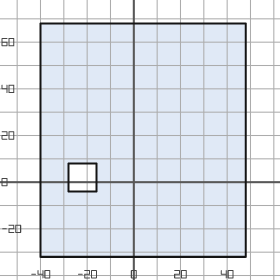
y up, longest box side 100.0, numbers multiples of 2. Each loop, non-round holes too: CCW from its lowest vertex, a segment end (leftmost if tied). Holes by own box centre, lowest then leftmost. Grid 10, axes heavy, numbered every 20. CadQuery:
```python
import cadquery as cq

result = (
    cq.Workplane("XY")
    .moveTo(-40.0, -32.0)
    .lineTo(48.0, -32.0)
    .lineTo(48.0, 68.0)
    .lineTo(-40.0, 68.0)
    .close()
    .moveTo(-28.0, -4.0)
    .lineTo(-16.0, -4.0)
    .lineTo(-16.0, 8.0)
    .lineTo(-28.0, 8.0)
    .close()
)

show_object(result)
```